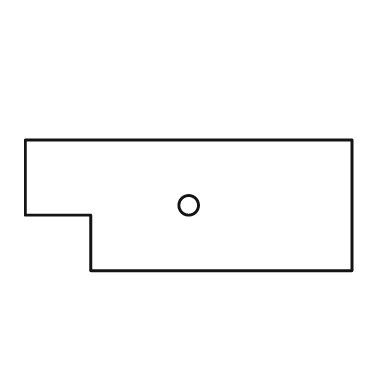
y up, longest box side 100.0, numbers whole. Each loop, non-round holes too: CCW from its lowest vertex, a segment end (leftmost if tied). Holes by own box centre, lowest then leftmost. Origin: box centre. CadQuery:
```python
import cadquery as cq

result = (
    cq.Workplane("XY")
    .moveTo(-30.0, -20.0)
    .lineTo(50.0, -20.0)
    .lineTo(50.0, 20.0)
    .lineTo(-50.0, 20.0)
    .lineTo(-50.0, -3.0)
    .lineTo(-30.0, -3.0)
    .close()
    .moveTo(0.0, 0.0)
    .circle(3.0)
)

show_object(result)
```